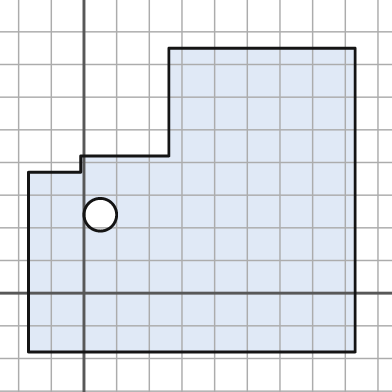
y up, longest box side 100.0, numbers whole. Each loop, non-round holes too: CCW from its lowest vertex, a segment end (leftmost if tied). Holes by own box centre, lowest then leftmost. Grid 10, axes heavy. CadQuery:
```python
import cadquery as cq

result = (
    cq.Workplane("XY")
    .moveTo(-17.0, -18.0)
    .lineTo(83.0, -18.0)
    .lineTo(83.0, 75.0)
    .lineTo(26.0, 75.0)
    .lineTo(26.0, 42.0)
    .lineTo(-1.0, 42.0)
    .lineTo(-1.0, 37.0)
    .lineTo(-17.0, 37.0)
    .close()
    .moveTo(5.0, 24.0)
    .circle(5.0)
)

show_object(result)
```